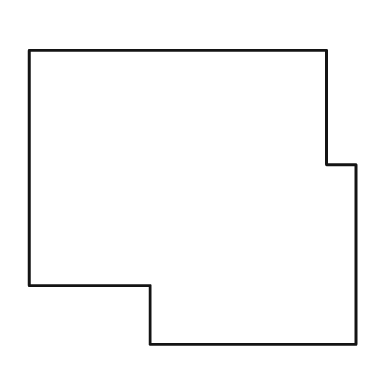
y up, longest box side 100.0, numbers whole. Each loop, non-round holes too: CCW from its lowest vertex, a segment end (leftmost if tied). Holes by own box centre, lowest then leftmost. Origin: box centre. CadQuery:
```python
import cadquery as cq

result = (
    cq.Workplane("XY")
    .moveTo(-13.0, -45.0)
    .lineTo(50.0, -45.0)
    .lineTo(50.0, 10.0)
    .lineTo(41.0, 10.0)
    .lineTo(41.0, 45.0)
    .lineTo(-50.0, 45.0)
    .lineTo(-50.0, -27.0)
    .lineTo(-13.0, -27.0)
    .close()
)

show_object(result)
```